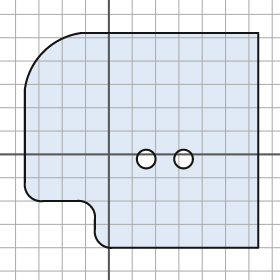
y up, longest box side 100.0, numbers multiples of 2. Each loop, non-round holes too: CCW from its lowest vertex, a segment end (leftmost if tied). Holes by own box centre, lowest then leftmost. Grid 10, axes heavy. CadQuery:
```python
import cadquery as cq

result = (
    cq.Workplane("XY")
    .moveTo(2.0, -40.0)
    .lineTo(64.0, -40.0)
    .lineTo(64.0, 52.0)
    .lineTo(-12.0, 52.0)
    .threePointArc((-28.0, 44.0), (-36.0, 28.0))
    .lineTo(-36.0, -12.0)
    .threePointArc((-34.0, -18.0), (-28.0, -20.0))
    .lineTo(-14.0, -20.0)
    .threePointArc((-8.0, -22.0), (-6.0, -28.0))
    .lineTo(-6.0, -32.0)
    .threePointArc((-4.0, -38.0), (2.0, -40.0))
    .close()
    .moveTo(16.0, -2.0)
    .circle(4.0)
    .moveTo(32.0, -2.0)
    .circle(4.0)
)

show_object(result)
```